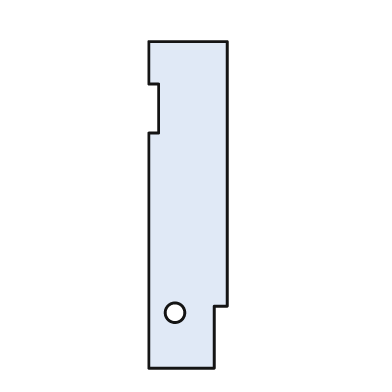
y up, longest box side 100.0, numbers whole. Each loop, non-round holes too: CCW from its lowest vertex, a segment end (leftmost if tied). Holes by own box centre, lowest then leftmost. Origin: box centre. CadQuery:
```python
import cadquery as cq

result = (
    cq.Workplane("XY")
    .moveTo(-12.0, -50.0)
    .lineTo(8.0, -50.0)
    .lineTo(8.0, -31.0)
    .lineTo(12.0, -31.0)
    .lineTo(12.0, 50.0)
    .lineTo(-12.0, 50.0)
    .lineTo(-12.0, 37.0)
    .lineTo(-9.0, 37.0)
    .lineTo(-9.0, 22.0)
    .lineTo(-12.0, 22.0)
    .close()
    .moveTo(-4.0, -33.0)
    .circle(3.0)
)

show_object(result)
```